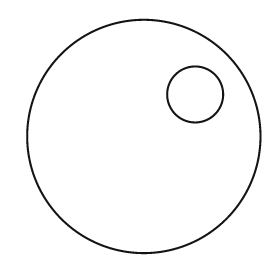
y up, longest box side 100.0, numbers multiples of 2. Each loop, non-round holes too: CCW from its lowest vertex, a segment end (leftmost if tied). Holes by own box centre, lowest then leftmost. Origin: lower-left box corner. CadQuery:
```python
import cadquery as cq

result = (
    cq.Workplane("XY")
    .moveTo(50.0, 50.0)
    .circle(50.0)
    .moveTo(72.0, 68.0)
    .circle(12.0)
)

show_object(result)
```